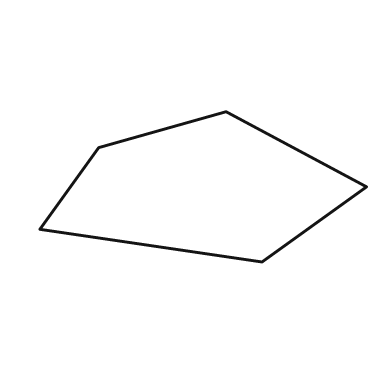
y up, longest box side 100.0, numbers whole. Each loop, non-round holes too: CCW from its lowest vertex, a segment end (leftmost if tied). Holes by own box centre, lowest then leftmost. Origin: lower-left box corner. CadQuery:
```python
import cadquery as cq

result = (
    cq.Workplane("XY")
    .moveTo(68.0, 0.0)
    .lineTo(100.0, 23.0)
    .lineTo(57.0, 46.0)
    .lineTo(18.0, 35.0)
    .lineTo(0.0, 10.0)
    .close()
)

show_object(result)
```